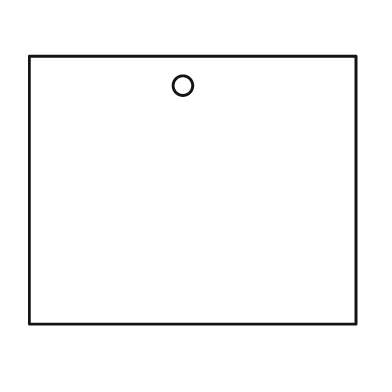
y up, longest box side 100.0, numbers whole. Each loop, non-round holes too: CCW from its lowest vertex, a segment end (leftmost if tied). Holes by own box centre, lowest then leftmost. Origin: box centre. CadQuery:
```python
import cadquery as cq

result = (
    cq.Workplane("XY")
    .moveTo(-50.0, -41.0)
    .lineTo(50.0, -41.0)
    .lineTo(50.0, 41.0)
    .lineTo(-50.0, 41.0)
    .close()
    .moveTo(-3.0, 32.0)
    .circle(3.0)
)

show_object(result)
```